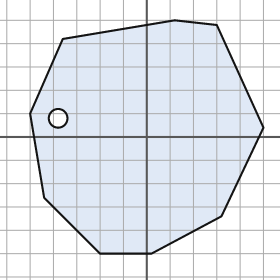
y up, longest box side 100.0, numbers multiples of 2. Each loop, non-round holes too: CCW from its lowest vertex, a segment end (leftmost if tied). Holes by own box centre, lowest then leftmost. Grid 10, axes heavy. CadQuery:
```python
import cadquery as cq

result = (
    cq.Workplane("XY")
    .moveTo(-20.0, -50.0)
    .lineTo(2.0, -50.0)
    .lineTo(32.0, -34.0)
    .lineTo(50.0, 4.0)
    .lineTo(30.0, 48.0)
    .lineTo(12.0, 50.0)
    .lineTo(-36.0, 42.0)
    .lineTo(-50.0, 10.0)
    .lineTo(-44.0, -26.0)
    .close()
    .moveTo(-38.0, 8.0)
    .circle(4.0)
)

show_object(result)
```